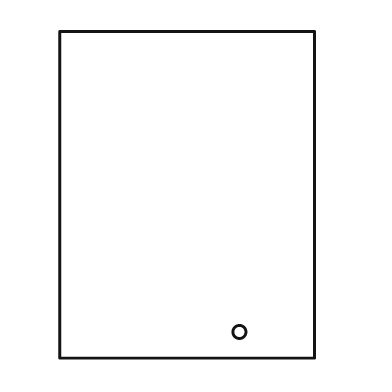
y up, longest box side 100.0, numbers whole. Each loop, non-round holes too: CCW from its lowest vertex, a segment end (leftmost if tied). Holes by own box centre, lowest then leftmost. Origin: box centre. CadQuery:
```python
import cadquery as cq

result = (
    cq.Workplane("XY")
    .moveTo(-39.0, -50.0)
    .lineTo(39.0, -50.0)
    .lineTo(39.0, 50.0)
    .lineTo(-39.0, 50.0)
    .close()
    .moveTo(16.0, -42.0)
    .circle(2.0)
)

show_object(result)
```